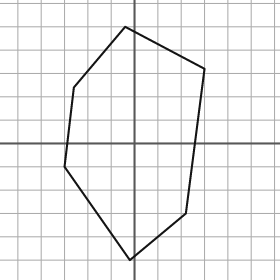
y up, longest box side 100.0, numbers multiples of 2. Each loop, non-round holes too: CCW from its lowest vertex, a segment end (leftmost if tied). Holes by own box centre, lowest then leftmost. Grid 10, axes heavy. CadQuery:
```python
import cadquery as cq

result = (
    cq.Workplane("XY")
    .moveTo(-2.0, -50.0)
    .lineTo(22.0, -30.0)
    .lineTo(30.0, 32.0)
    .lineTo(-4.0, 50.0)
    .lineTo(-26.0, 24.0)
    .lineTo(-30.0, -10.0)
    .close()
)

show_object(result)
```